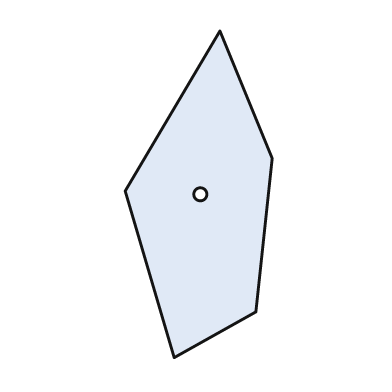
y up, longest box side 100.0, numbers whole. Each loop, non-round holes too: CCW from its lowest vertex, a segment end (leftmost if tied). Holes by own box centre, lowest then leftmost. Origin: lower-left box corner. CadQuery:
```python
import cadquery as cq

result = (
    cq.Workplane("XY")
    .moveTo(15.0, 0.0)
    .lineTo(40.0, 14.0)
    .lineTo(45.0, 61.0)
    .lineTo(29.0, 100.0)
    .lineTo(0.0, 51.0)
    .close()
    .moveTo(23.0, 50.0)
    .circle(2.0)
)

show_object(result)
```